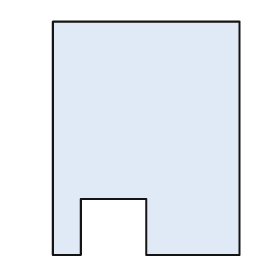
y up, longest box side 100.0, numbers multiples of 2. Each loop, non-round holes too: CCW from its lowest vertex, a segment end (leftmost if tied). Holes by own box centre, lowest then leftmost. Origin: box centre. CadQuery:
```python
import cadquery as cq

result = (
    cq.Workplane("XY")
    .moveTo(-40.0, -50.0)
    .lineTo(-28.0, -50.0)
    .lineTo(-28.0, -26.0)
    .lineTo(0.0, -26.0)
    .lineTo(0.0, -50.0)
    .lineTo(40.0, -50.0)
    .lineTo(40.0, 50.0)
    .lineTo(-40.0, 50.0)
    .close()
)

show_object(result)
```